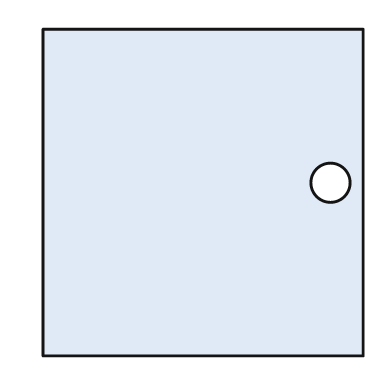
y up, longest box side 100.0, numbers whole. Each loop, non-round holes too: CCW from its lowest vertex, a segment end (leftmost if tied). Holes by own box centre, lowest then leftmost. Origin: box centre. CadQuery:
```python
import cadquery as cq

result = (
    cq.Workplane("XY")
    .moveTo(-49.0, -50.0)
    .lineTo(49.0, -50.0)
    .lineTo(49.0, 50.0)
    .lineTo(-49.0, 50.0)
    .close()
    .moveTo(39.0, 3.0)
    .circle(6.0)
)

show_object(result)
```